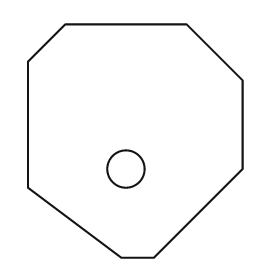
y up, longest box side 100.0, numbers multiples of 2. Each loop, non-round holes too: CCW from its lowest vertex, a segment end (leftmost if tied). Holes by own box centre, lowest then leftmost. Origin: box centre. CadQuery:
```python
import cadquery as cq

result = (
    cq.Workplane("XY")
    .moveTo(-6.0, -50.0)
    .lineTo(8.0, -50.0)
    .lineTo(46.0, -12.0)
    .lineTo(46.0, 26.0)
    .lineTo(22.0, 50.0)
    .lineTo(-30.0, 50.0)
    .lineTo(-46.0, 34.0)
    .lineTo(-46.0, -20.0)
    .close()
    .moveTo(-4.0, -12.0)
    .circle(8.0)
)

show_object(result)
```